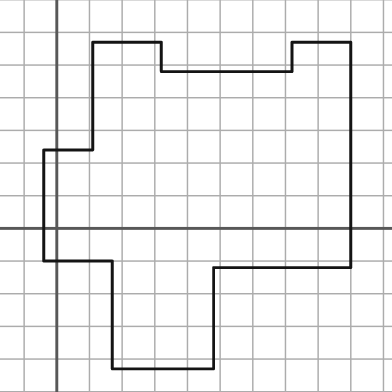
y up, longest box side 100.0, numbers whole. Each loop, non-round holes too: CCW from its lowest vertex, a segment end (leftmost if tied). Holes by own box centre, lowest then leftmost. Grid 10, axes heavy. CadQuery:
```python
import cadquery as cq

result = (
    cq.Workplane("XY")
    .moveTo(17.0, -43.0)
    .lineTo(48.0, -43.0)
    .lineTo(48.0, -12.0)
    .lineTo(90.0, -12.0)
    .lineTo(90.0, 57.0)
    .lineTo(72.0, 57.0)
    .lineTo(72.0, 48.0)
    .lineTo(32.0, 48.0)
    .lineTo(32.0, 57.0)
    .lineTo(11.0, 57.0)
    .lineTo(11.0, 24.0)
    .lineTo(-4.0, 24.0)
    .lineTo(-4.0, -10.0)
    .lineTo(17.0, -10.0)
    .close()
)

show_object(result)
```